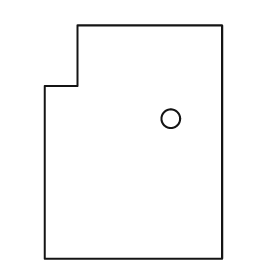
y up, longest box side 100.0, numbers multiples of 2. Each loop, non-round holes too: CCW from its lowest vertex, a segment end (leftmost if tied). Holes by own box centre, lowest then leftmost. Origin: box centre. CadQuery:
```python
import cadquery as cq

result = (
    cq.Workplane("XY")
    .moveTo(-38.0, -50.0)
    .lineTo(38.0, -50.0)
    .lineTo(38.0, 50.0)
    .lineTo(-24.0, 50.0)
    .lineTo(-24.0, 24.0)
    .lineTo(-38.0, 24.0)
    .close()
    .moveTo(16.0, 10.0)
    .circle(4.0)
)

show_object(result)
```